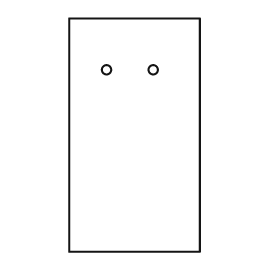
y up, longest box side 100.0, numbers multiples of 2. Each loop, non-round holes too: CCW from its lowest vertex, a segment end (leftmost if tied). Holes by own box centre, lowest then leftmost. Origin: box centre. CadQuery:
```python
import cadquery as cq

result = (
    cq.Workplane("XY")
    .moveTo(-28.0, -50.0)
    .lineTo(28.0, -50.0)
    .lineTo(28.0, 50.0)
    .lineTo(-28.0, 50.0)
    .close()
    .moveTo(-12.0, 28.0)
    .circle(2.0)
    .moveTo(8.0, 28.0)
    .circle(2.0)
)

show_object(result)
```